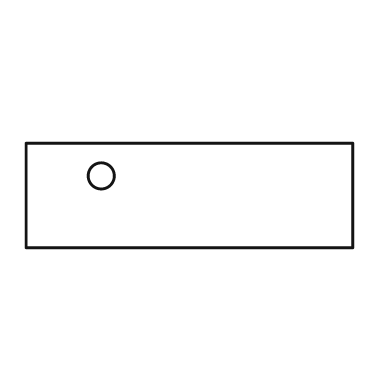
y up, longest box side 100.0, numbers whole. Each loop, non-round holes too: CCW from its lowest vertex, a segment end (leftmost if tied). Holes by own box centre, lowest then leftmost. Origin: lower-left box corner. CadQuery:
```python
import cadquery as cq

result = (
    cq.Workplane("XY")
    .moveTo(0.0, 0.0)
    .lineTo(100.0, 0.0)
    .lineTo(100.0, 32.0)
    .lineTo(0.0, 32.0)
    .close()
    .moveTo(23.0, 22.0)
    .circle(4.0)
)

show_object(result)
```